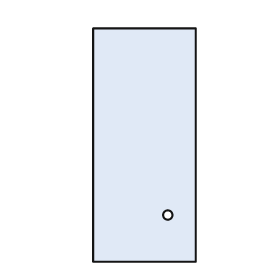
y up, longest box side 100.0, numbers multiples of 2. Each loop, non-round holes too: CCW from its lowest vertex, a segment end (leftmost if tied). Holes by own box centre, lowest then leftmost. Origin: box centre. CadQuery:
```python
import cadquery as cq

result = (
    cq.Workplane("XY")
    .moveTo(-22.0, -50.0)
    .lineTo(22.0, -50.0)
    .lineTo(22.0, 50.0)
    .lineTo(-22.0, 50.0)
    .close()
    .moveTo(10.0, -30.0)
    .circle(2.0)
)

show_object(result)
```